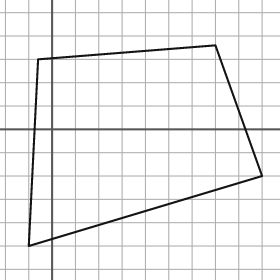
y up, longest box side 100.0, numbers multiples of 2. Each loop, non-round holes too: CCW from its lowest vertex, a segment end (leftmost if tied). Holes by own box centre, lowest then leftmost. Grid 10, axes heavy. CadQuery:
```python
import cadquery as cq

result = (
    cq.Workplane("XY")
    .moveTo(-10.0, -50.0)
    .lineTo(90.0, -20.0)
    .lineTo(70.0, 36.0)
    .lineTo(-6.0, 30.0)
    .close()
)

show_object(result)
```